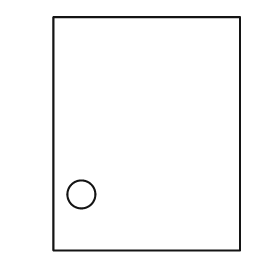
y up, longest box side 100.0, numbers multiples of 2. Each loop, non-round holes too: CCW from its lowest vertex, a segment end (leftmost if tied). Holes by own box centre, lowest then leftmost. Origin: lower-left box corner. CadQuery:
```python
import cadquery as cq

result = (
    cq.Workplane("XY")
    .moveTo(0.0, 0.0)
    .lineTo(80.0, 0.0)
    .lineTo(80.0, 100.0)
    .lineTo(0.0, 100.0)
    .close()
    .moveTo(12.0, 24.0)
    .circle(6.0)
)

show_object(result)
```